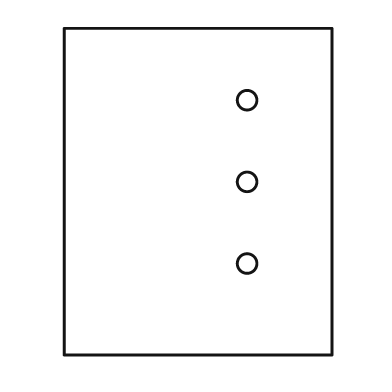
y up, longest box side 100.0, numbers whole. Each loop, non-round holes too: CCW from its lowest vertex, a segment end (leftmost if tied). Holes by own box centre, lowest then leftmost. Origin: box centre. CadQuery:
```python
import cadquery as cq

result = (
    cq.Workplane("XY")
    .moveTo(-41.0, -50.0)
    .lineTo(41.0, -50.0)
    .lineTo(41.0, 50.0)
    .lineTo(-41.0, 50.0)
    .close()
    .moveTo(15.0, -22.0)
    .circle(3.0)
    .moveTo(15.0, 3.0)
    .circle(3.0)
    .moveTo(15.0, 28.0)
    .circle(3.0)
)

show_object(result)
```